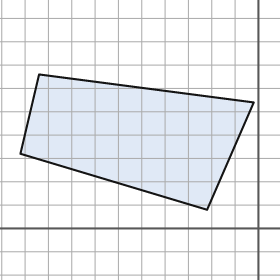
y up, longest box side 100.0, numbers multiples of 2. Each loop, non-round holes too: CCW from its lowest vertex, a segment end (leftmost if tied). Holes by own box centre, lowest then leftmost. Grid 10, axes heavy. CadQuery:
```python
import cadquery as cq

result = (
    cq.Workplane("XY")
    .moveTo(-22.0, 8.0)
    .lineTo(-2.0, 54.0)
    .lineTo(-94.0, 66.0)
    .lineTo(-102.0, 32.0)
    .close()
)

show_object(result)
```